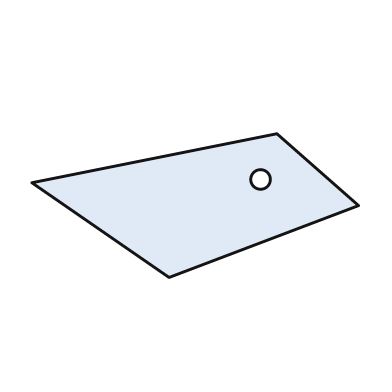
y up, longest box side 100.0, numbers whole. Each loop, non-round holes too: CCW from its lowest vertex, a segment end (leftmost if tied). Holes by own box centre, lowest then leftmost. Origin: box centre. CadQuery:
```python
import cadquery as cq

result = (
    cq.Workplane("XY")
    .moveTo(-8.0, -22.0)
    .lineTo(50.0, 0.0)
    .lineTo(25.0, 22.0)
    .lineTo(-50.0, 7.0)
    .close()
    .moveTo(20.0, 8.0)
    .circle(3.0)
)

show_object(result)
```